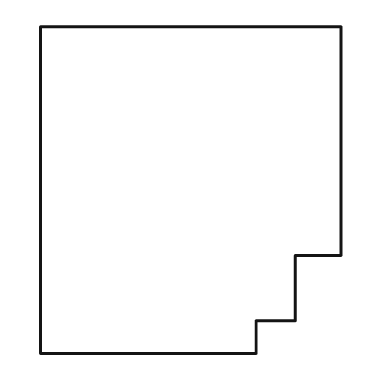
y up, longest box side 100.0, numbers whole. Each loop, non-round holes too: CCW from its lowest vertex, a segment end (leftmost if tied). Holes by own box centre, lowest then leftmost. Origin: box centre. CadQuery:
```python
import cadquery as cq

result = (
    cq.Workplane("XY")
    .moveTo(-46.0, -50.0)
    .lineTo(20.0, -50.0)
    .lineTo(20.0, -40.0)
    .lineTo(32.0, -40.0)
    .lineTo(32.0, -20.0)
    .lineTo(46.0, -20.0)
    .lineTo(46.0, 50.0)
    .lineTo(-46.0, 50.0)
    .close()
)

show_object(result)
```